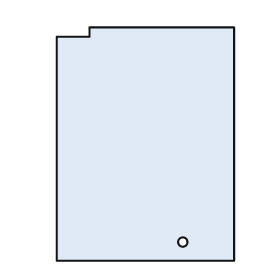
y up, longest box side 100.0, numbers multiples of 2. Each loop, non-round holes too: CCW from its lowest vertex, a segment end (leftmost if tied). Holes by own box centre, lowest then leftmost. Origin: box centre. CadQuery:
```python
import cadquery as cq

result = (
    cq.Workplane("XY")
    .moveTo(-38.0, -50.0)
    .lineTo(38.0, -50.0)
    .lineTo(38.0, 50.0)
    .lineTo(-24.0, 50.0)
    .lineTo(-24.0, 46.0)
    .lineTo(-38.0, 46.0)
    .close()
    .moveTo(16.0, -42.0)
    .circle(2.0)
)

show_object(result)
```